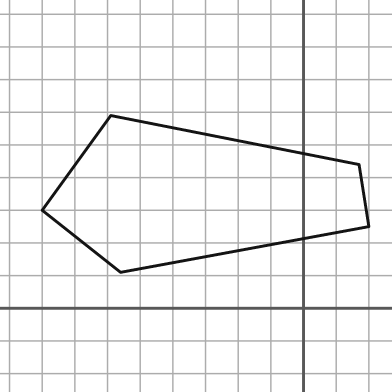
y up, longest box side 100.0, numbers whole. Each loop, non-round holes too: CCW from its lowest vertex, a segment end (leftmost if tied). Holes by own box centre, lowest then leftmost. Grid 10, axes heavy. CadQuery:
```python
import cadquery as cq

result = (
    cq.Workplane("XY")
    .moveTo(-56.0, 11.0)
    .lineTo(20.0, 25.0)
    .lineTo(17.0, 44.0)
    .lineTo(-59.0, 59.0)
    .lineTo(-80.0, 30.0)
    .close()
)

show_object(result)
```